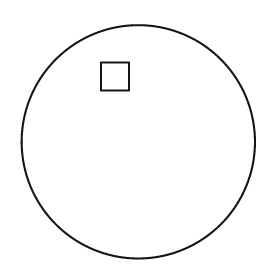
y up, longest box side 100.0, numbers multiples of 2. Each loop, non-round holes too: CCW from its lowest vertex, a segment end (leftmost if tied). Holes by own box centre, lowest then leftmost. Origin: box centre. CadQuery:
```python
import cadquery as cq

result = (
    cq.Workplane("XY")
    .moveTo(0.0, 0.0)
    .circle(50.0)
    .moveTo(-16.0, 22.0)
    .lineTo(-4.0, 22.0)
    .lineTo(-4.0, 34.0)
    .lineTo(-16.0, 34.0)
    .close()
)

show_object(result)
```